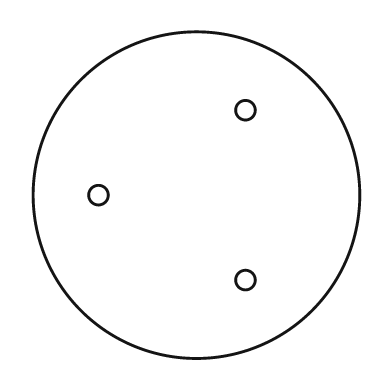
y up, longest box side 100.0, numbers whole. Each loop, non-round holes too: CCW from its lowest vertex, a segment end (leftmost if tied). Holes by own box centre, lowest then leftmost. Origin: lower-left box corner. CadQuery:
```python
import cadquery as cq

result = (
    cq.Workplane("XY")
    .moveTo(50.0, 50.0)
    .circle(50.0)
    .moveTo(65.0, 24.0)
    .circle(3.0)
    .moveTo(20.0, 50.0)
    .circle(3.0)
    .moveTo(65.0, 76.0)
    .circle(3.0)
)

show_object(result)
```